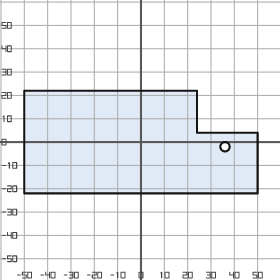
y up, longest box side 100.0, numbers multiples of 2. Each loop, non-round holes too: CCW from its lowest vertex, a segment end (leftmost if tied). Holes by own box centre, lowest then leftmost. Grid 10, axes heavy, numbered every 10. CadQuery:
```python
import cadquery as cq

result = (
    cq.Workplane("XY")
    .moveTo(-50.0, -22.0)
    .lineTo(50.0, -22.0)
    .lineTo(50.0, 4.0)
    .lineTo(24.0, 4.0)
    .lineTo(24.0, 22.0)
    .lineTo(-50.0, 22.0)
    .close()
    .moveTo(36.0, -2.0)
    .circle(2.0)
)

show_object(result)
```